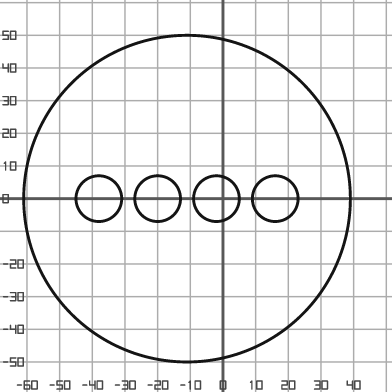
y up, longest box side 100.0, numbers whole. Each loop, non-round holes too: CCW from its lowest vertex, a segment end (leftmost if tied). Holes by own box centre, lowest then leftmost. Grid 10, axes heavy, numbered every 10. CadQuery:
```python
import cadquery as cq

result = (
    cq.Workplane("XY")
    .moveTo(-11.0, 0.0)
    .circle(50.0)
    .moveTo(-38.0, 0.0)
    .circle(7.0)
    .moveTo(-20.0, 0.0)
    .circle(7.0)
    .moveTo(-2.0, 0.0)
    .circle(7.0)
    .moveTo(16.0, 0.0)
    .circle(7.0)
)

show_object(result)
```